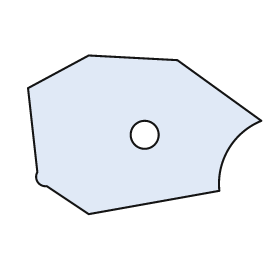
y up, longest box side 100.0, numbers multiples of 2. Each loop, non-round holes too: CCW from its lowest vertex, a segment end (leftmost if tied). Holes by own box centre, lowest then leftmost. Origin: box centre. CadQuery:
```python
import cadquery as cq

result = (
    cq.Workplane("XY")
    .moveTo(-24.0, -34.0)
    .lineTo(32.0, -24.0)
    .threePointArc((36.0, -6.0), (50.0, 6.0))
    .lineTo(14.0, 32.0)
    .lineTo(-24.0, 34.0)
    .lineTo(-50.0, 20.0)
    .lineTo(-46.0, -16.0)
    .threePointArc((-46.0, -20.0), (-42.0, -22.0))
    .close()
    .moveTo(0.0, 0.0)
    .circle(6.0)
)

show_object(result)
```